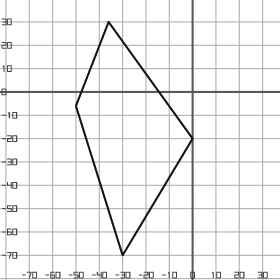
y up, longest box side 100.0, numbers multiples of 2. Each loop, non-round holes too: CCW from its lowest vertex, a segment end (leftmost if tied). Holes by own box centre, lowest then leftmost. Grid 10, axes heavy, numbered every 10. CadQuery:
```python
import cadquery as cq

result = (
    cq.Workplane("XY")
    .moveTo(-30.0, -70.0)
    .lineTo(0.0, -20.0)
    .lineTo(-36.0, 30.0)
    .lineTo(-50.0, -6.0)
    .close()
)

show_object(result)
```